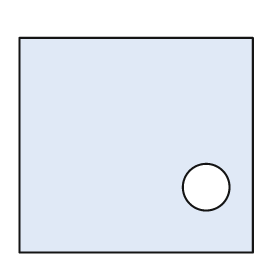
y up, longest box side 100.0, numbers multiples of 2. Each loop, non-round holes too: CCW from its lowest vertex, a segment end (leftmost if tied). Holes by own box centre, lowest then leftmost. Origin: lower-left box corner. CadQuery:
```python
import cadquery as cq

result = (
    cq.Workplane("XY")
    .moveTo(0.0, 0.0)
    .lineTo(100.0, 0.0)
    .lineTo(100.0, 92.0)
    .lineTo(0.0, 92.0)
    .close()
    .moveTo(80.0, 28.0)
    .circle(10.0)
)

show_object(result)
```